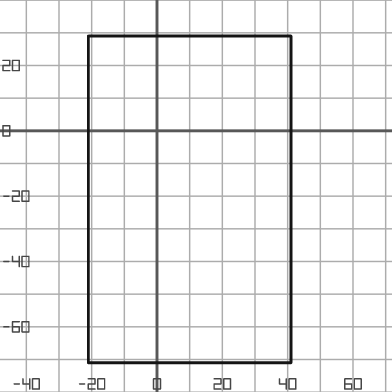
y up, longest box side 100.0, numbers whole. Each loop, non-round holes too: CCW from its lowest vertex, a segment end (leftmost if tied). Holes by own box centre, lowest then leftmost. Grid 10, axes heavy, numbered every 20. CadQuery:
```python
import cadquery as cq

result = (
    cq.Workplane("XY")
    .moveTo(-21.0, -71.0)
    .lineTo(41.0, -71.0)
    .lineTo(41.0, 29.0)
    .lineTo(-21.0, 29.0)
    .close()
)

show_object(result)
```